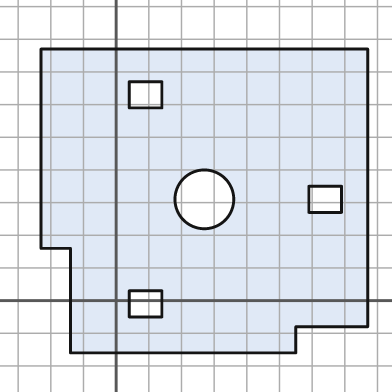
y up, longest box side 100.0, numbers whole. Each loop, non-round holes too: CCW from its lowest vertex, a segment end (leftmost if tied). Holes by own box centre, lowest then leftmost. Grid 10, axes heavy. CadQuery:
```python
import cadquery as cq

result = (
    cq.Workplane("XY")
    .moveTo(-14.0, -16.0)
    .lineTo(55.0, -16.0)
    .lineTo(55.0, -8.0)
    .lineTo(77.0, -8.0)
    .lineTo(77.0, 77.0)
    .lineTo(-23.0, 77.0)
    .lineTo(-23.0, 16.0)
    .lineTo(-14.0, 16.0)
    .close()
    .moveTo(4.0, -5.0)
    .lineTo(14.0, -5.0)
    .lineTo(14.0, 3.0)
    .lineTo(4.0, 3.0)
    .close()
    .moveTo(27.0, 31.0)
    .circle(9.0)
    .moveTo(59.0, 27.0)
    .lineTo(69.0, 27.0)
    .lineTo(69.0, 35.0)
    .lineTo(59.0, 35.0)
    .close()
    .moveTo(4.0, 59.0)
    .lineTo(14.0, 59.0)
    .lineTo(14.0, 67.0)
    .lineTo(4.0, 67.0)
    .close()
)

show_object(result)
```